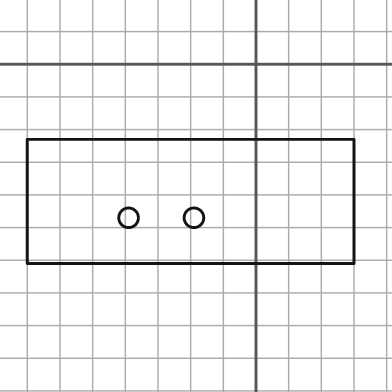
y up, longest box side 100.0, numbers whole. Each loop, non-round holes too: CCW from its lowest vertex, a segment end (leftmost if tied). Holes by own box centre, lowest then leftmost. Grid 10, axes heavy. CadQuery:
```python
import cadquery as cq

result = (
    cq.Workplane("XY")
    .moveTo(-70.0, -61.0)
    .lineTo(30.0, -61.0)
    .lineTo(30.0, -23.0)
    .lineTo(-70.0, -23.0)
    .close()
    .moveTo(-39.0, -47.0)
    .circle(3.0)
    .moveTo(-19.0, -47.0)
    .circle(3.0)
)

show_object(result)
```